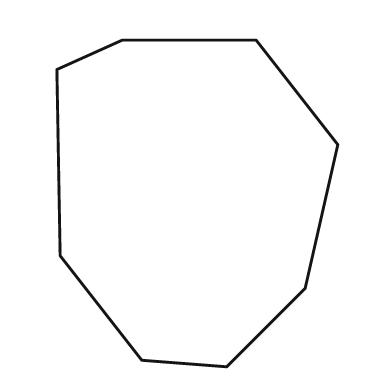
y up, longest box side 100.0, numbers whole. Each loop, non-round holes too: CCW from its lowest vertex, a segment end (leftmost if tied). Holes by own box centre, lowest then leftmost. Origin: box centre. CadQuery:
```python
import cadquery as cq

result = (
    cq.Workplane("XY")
    .moveTo(9.0, -50.0)
    .lineTo(33.0, -26.0)
    .lineTo(43.0, 18.0)
    .lineTo(18.0, 50.0)
    .lineTo(-23.0, 50.0)
    .lineTo(-43.0, 41.0)
    .lineTo(-42.0, -16.0)
    .lineTo(-17.0, -48.0)
    .close()
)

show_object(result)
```